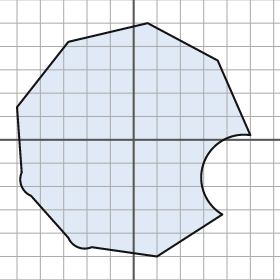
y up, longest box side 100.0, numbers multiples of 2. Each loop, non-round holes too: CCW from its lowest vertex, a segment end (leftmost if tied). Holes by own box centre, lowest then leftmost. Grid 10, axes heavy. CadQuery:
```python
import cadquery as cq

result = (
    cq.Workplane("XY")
    .moveTo(10.0, -50.0)
    .lineTo(38.0, -32.0)
    .threePointArc((30.0, -10.0), (50.0, 2.0))
    .lineTo(36.0, 34.0)
    .lineTo(6.0, 50.0)
    .lineTo(-28.0, 42.0)
    .lineTo(-50.0, 14.0)
    .lineTo(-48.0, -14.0)
    .threePointArc((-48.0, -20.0), (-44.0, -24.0))
    .lineTo(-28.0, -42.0)
    .threePointArc((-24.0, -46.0), (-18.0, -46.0))
    .close()
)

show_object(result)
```